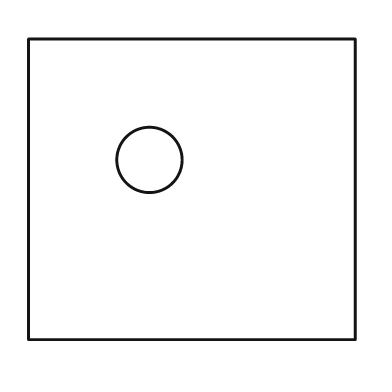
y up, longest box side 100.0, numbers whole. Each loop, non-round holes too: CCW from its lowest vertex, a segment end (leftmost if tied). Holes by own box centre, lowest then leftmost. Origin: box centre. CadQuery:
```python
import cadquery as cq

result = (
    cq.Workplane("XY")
    .moveTo(-50.0, -46.0)
    .lineTo(50.0, -46.0)
    .lineTo(50.0, 46.0)
    .lineTo(-50.0, 46.0)
    .close()
    .moveTo(-13.0, 9.0)
    .circle(10.0)
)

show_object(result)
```